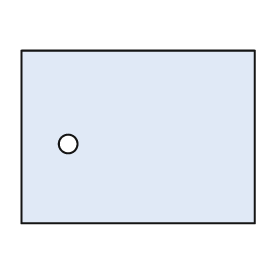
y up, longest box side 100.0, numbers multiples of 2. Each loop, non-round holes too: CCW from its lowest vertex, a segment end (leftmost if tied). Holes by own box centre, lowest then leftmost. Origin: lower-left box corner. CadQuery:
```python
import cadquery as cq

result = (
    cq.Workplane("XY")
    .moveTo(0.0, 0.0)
    .lineTo(100.0, 0.0)
    .lineTo(100.0, 74.0)
    .lineTo(0.0, 74.0)
    .close()
    .moveTo(20.0, 34.0)
    .circle(4.0)
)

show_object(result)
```